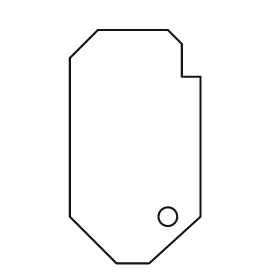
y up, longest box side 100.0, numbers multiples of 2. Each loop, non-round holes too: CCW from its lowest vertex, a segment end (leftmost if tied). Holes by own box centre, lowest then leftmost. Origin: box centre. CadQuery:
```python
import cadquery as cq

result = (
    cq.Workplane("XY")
    .moveTo(-8.0, -50.0)
    .lineTo(6.0, -50.0)
    .lineTo(28.0, -30.0)
    .lineTo(28.0, 30.0)
    .lineTo(20.0, 30.0)
    .lineTo(20.0, 44.0)
    .lineTo(14.0, 50.0)
    .lineTo(-16.0, 50.0)
    .lineTo(-28.0, 38.0)
    .lineTo(-28.0, -30.0)
    .close()
    .moveTo(14.0, -30.0)
    .circle(4.0)
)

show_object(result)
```